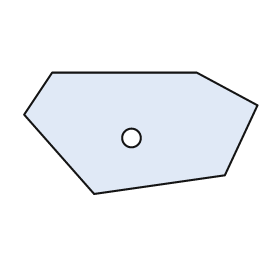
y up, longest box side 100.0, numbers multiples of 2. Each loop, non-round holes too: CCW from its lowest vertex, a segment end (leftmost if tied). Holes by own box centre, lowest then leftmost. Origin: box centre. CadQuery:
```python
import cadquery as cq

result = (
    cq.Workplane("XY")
    .moveTo(-20.0, -26.0)
    .lineTo(36.0, -18.0)
    .lineTo(50.0, 12.0)
    .lineTo(24.0, 26.0)
    .lineTo(-38.0, 26.0)
    .lineTo(-50.0, 8.0)
    .close()
    .moveTo(-4.0, -2.0)
    .circle(4.0)
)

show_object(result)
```